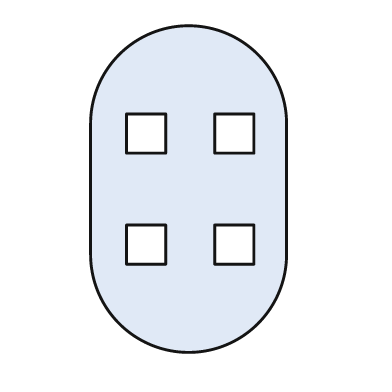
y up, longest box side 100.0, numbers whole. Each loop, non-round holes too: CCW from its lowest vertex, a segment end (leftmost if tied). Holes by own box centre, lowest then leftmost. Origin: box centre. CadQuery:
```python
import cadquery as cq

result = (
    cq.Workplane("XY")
    .moveTo(-30.0, -20.0)
    .threePointArc((0.0, -50.0), (30.0, -20.0))
    .lineTo(30.0, 20.0)
    .threePointArc((0.0, 50.0), (-30.0, 20.0))
    .close()
    .moveTo(-19.0, -23.0)
    .lineTo(-7.0, -23.0)
    .lineTo(-7.0, -11.0)
    .lineTo(-19.0, -11.0)
    .close()
    .moveTo(8.0, -23.0)
    .lineTo(20.0, -23.0)
    .lineTo(20.0, -11.0)
    .lineTo(8.0, -11.0)
    .close()
    .moveTo(-19.0, 11.0)
    .lineTo(-7.0, 11.0)
    .lineTo(-7.0, 23.0)
    .lineTo(-19.0, 23.0)
    .close()
    .moveTo(8.0, 11.0)
    .lineTo(20.0, 11.0)
    .lineTo(20.0, 23.0)
    .lineTo(8.0, 23.0)
    .close()
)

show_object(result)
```